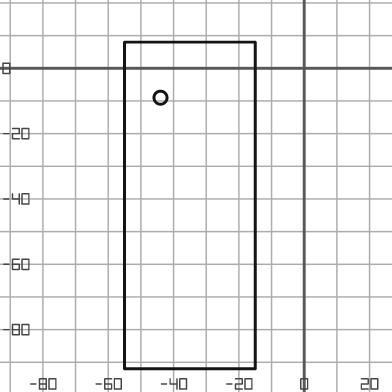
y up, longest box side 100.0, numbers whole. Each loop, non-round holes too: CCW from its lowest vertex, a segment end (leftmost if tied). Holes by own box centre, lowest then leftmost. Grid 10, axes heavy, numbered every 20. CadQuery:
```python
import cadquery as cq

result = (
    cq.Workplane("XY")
    .moveTo(-55.0, -92.0)
    .lineTo(-15.0, -92.0)
    .lineTo(-15.0, 8.0)
    .lineTo(-55.0, 8.0)
    .close()
    .moveTo(-44.0, -9.0)
    .circle(2.0)
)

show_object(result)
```